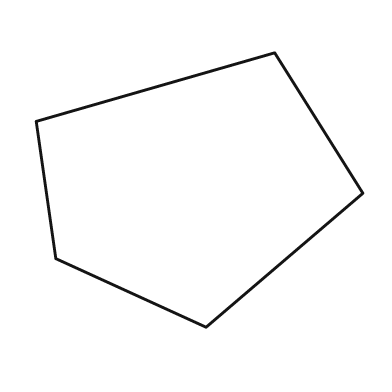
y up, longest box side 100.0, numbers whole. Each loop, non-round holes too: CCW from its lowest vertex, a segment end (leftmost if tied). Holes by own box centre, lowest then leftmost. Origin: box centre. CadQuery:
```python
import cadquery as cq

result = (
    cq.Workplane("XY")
    .moveTo(2.0, -42.0)
    .lineTo(50.0, -1.0)
    .lineTo(23.0, 42.0)
    .lineTo(-50.0, 21.0)
    .lineTo(-44.0, -21.0)
    .close()
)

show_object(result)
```